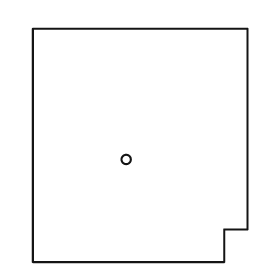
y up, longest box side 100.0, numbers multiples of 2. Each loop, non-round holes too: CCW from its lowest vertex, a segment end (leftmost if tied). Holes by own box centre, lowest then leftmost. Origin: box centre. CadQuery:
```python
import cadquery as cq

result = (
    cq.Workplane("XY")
    .moveTo(-46.0, -50.0)
    .lineTo(36.0, -50.0)
    .lineTo(36.0, -36.0)
    .lineTo(46.0, -36.0)
    .lineTo(46.0, 50.0)
    .lineTo(-46.0, 50.0)
    .close()
    .moveTo(-6.0, -6.0)
    .circle(2.0)
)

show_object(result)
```